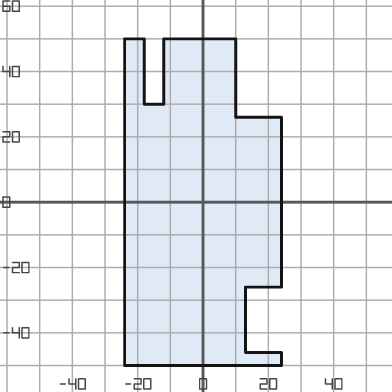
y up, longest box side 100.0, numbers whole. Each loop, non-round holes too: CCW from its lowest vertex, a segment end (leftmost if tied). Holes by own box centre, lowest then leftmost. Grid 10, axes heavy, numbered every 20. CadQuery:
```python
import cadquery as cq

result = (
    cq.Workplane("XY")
    .moveTo(-24.0, -50.0)
    .lineTo(24.0, -50.0)
    .lineTo(24.0, -46.0)
    .lineTo(13.0, -46.0)
    .lineTo(13.0, -26.0)
    .lineTo(24.0, -26.0)
    .lineTo(24.0, 26.0)
    .lineTo(10.0, 26.0)
    .lineTo(10.0, 50.0)
    .lineTo(-12.0, 50.0)
    .lineTo(-12.0, 30.0)
    .lineTo(-18.0, 30.0)
    .lineTo(-18.0, 50.0)
    .lineTo(-24.0, 50.0)
    .close()
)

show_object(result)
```